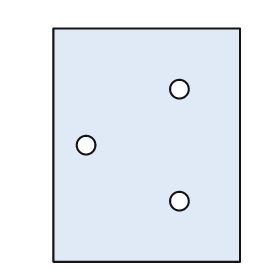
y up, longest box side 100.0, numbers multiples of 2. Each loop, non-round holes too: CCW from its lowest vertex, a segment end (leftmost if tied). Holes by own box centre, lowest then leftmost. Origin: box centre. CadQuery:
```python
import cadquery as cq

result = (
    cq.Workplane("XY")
    .moveTo(-40.0, -50.0)
    .lineTo(40.0, -50.0)
    .lineTo(40.0, 50.0)
    .lineTo(-40.0, 50.0)
    .close()
    .moveTo(14.0, -24.0)
    .circle(4.0)
    .moveTo(-26.0, 0.0)
    .circle(4.0)
    .moveTo(14.0, 24.0)
    .circle(4.0)
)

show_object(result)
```